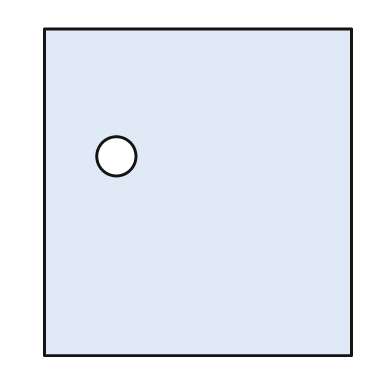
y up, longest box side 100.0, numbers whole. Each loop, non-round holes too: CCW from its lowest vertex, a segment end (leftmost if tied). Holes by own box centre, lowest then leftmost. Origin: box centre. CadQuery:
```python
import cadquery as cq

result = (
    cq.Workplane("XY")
    .moveTo(-47.0, -50.0)
    .lineTo(47.0, -50.0)
    .lineTo(47.0, 50.0)
    .lineTo(-47.0, 50.0)
    .close()
    .moveTo(-25.0, 11.0)
    .circle(6.0)
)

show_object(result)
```